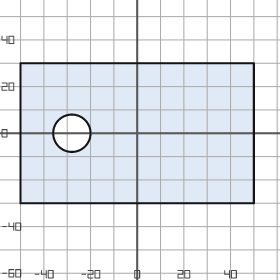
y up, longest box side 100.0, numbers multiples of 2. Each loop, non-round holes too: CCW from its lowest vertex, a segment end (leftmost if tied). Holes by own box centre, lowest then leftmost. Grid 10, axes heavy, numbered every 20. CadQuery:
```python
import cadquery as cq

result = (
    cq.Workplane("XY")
    .moveTo(-50.0, -30.0)
    .lineTo(50.0, -30.0)
    .lineTo(50.0, 30.0)
    .lineTo(-50.0, 30.0)
    .close()
    .moveTo(-28.0, 0.0)
    .circle(8.0)
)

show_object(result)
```